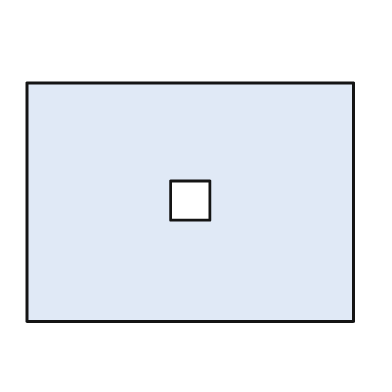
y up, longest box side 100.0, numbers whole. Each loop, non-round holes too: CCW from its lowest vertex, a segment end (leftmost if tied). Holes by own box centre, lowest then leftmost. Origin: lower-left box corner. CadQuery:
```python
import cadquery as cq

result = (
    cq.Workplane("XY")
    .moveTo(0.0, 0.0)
    .lineTo(100.0, 0.0)
    .lineTo(100.0, 73.0)
    .lineTo(0.0, 73.0)
    .close()
    .moveTo(44.0, 31.0)
    .lineTo(56.0, 31.0)
    .lineTo(56.0, 43.0)
    .lineTo(44.0, 43.0)
    .close()
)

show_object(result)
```